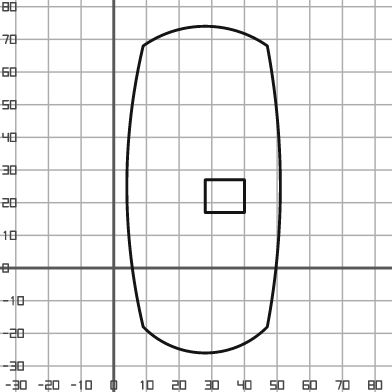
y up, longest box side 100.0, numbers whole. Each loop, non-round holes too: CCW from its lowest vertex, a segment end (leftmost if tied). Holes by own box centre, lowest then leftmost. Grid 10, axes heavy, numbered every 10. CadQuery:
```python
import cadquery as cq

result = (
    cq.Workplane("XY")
    .moveTo(9.0, -18.0)
    .threePointArc((28.0, -26.0), (47.0, -18.0))
    .threePointArc((51.0, 25.0), (47.0, 68.0))
    .threePointArc((28.0, 74.0), (9.0, 68.0))
    .threePointArc((4.0, 25.0), (9.0, -18.0))
    .close()
    .moveTo(28.0, 17.0)
    .lineTo(40.0, 17.0)
    .lineTo(40.0, 27.0)
    .lineTo(28.0, 27.0)
    .close()
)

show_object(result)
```